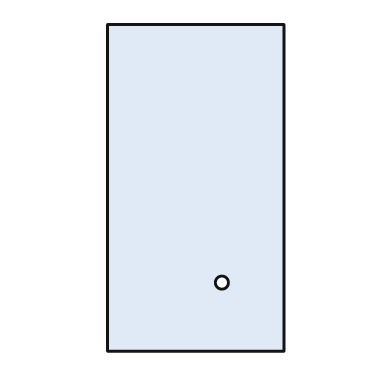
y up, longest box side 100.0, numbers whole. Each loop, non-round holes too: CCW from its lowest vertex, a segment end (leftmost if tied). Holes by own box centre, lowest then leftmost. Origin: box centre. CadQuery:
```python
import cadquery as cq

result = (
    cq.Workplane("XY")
    .moveTo(-27.0, -50.0)
    .lineTo(27.0, -50.0)
    .lineTo(27.0, 50.0)
    .lineTo(-27.0, 50.0)
    .close()
    .moveTo(8.0, -29.0)
    .circle(2.0)
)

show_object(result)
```